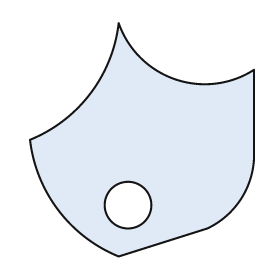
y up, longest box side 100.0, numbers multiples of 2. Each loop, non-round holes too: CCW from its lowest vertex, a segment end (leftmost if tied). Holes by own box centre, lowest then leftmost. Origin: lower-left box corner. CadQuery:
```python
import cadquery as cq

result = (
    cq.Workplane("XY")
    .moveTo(38.0, 0.0)
    .lineTo(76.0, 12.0)
    .threePointArc((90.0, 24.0), (96.0, 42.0))
    .lineTo(96.0, 80.0)
    .threePointArc((62.0, 76.0), (38.0, 100.0))
    .threePointArc((26.0, 70.0), (0.0, 50.0))
    .threePointArc((12.0, 20.0), (38.0, 0.0))
    .close()
    .moveTo(42.0, 22.0)
    .circle(10.0)
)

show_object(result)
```